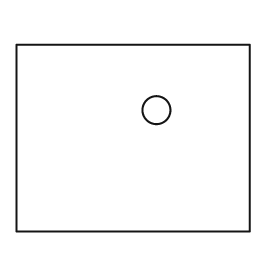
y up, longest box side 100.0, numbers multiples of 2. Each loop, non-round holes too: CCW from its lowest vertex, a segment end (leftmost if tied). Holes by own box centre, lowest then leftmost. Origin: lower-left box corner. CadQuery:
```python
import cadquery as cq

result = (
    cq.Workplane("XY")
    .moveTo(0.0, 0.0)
    .lineTo(100.0, 0.0)
    .lineTo(100.0, 80.0)
    .lineTo(0.0, 80.0)
    .close()
    .moveTo(60.0, 52.0)
    .circle(6.0)
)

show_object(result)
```